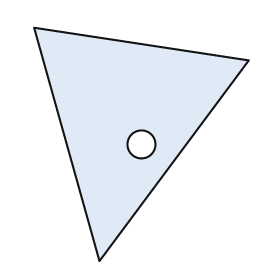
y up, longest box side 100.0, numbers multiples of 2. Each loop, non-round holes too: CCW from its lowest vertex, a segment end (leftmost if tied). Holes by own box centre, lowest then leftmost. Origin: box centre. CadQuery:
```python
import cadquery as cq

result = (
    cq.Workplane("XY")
    .moveTo(-18.0, -50.0)
    .lineTo(46.0, 36.0)
    .lineTo(-46.0, 50.0)
    .close()
    .moveTo(0.0, 0.0)
    .circle(6.0)
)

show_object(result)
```